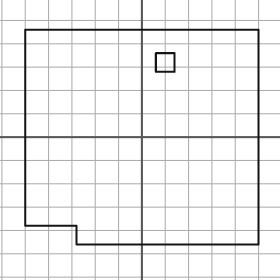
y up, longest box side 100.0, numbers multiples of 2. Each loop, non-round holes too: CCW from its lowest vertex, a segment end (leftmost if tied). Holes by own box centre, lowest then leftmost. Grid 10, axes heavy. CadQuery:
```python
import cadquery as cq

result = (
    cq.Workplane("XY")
    .moveTo(-28.0, -46.0)
    .lineTo(50.0, -46.0)
    .lineTo(50.0, 46.0)
    .lineTo(-50.0, 46.0)
    .lineTo(-50.0, -38.0)
    .lineTo(-28.0, -38.0)
    .close()
    .moveTo(6.0, 28.0)
    .lineTo(14.0, 28.0)
    .lineTo(14.0, 36.0)
    .lineTo(6.0, 36.0)
    .close()
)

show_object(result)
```